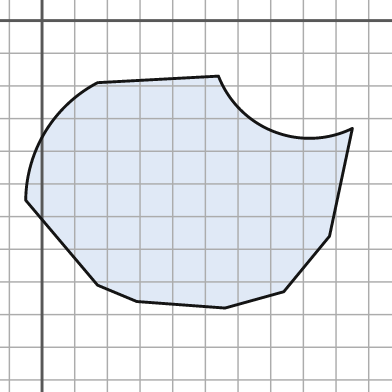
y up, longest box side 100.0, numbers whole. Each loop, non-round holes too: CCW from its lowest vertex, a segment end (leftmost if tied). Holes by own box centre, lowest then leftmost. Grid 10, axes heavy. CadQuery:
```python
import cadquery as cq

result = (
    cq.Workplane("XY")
    .moveTo(56.0, -88.0)
    .lineTo(74.0, -83.0)
    .lineTo(88.0, -66.0)
    .lineTo(95.0, -33.0)
    .threePointArc((71.0, -34.0), (54.0, -17.0))
    .lineTo(17.0, -19.0)
    .threePointArc((1.0, -34.0), (-5.0, -55.0))
    .lineTo(17.0, -81.0)
    .lineTo(29.0, -86.0)
    .close()
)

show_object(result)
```